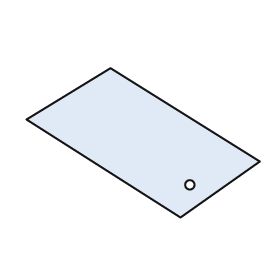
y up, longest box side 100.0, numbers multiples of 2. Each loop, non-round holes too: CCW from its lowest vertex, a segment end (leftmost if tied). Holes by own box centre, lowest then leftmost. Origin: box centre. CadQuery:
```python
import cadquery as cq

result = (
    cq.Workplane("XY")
    .moveTo(16.0, -32.0)
    .lineTo(50.0, -8.0)
    .lineTo(-14.0, 32.0)
    .lineTo(-50.0, 10.0)
    .close()
    .moveTo(20.0, -18.0)
    .circle(2.0)
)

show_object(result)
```